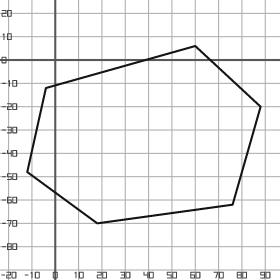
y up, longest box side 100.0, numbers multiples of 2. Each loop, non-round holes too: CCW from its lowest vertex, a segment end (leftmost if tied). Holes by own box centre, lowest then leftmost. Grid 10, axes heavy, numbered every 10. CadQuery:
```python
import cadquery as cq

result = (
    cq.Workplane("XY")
    .moveTo(18.0, -70.0)
    .lineTo(76.0, -62.0)
    .lineTo(88.0, -20.0)
    .lineTo(60.0, 6.0)
    .lineTo(-4.0, -12.0)
    .lineTo(-12.0, -48.0)
    .close()
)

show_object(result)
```